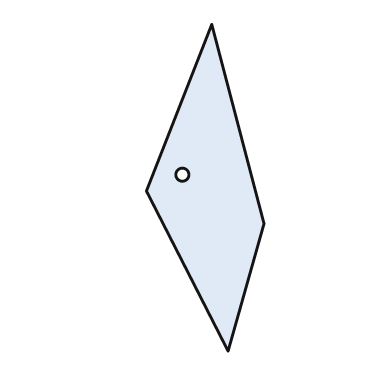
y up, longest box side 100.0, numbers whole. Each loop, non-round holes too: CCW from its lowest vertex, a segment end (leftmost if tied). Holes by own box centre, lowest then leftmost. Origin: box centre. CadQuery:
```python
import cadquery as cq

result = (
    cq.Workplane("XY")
    .moveTo(7.0, -50.0)
    .lineTo(18.0, -11.0)
    .lineTo(2.0, 50.0)
    .lineTo(-18.0, -1.0)
    .close()
    .moveTo(-7.0, 4.0)
    .circle(2.0)
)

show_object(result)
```